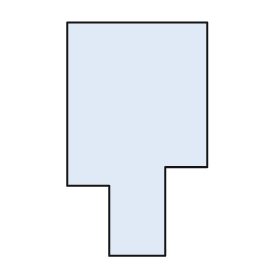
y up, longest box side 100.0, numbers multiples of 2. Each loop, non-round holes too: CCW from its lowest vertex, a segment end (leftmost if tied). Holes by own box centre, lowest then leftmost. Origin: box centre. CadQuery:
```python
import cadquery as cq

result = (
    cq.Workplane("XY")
    .moveTo(-12.0, -50.0)
    .lineTo(12.0, -50.0)
    .lineTo(12.0, -12.0)
    .lineTo(30.0, -12.0)
    .lineTo(30.0, 50.0)
    .lineTo(-30.0, 50.0)
    .lineTo(-30.0, -20.0)
    .lineTo(-12.0, -20.0)
    .close()
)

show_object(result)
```